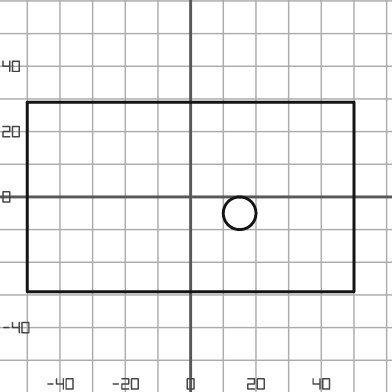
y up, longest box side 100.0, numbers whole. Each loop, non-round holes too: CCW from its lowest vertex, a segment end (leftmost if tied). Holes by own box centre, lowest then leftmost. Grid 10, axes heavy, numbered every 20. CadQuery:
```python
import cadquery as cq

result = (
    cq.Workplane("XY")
    .moveTo(-50.0, -29.0)
    .lineTo(50.0, -29.0)
    .lineTo(50.0, 29.0)
    .lineTo(-50.0, 29.0)
    .close()
    .moveTo(15.0, -5.0)
    .circle(5.0)
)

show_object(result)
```